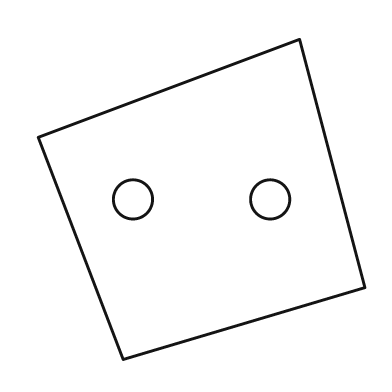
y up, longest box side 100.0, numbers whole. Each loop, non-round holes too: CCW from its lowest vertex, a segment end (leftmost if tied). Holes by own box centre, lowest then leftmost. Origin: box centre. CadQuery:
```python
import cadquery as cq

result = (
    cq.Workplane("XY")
    .moveTo(-24.0, -49.0)
    .lineTo(50.0, -27.0)
    .lineTo(30.0, 49.0)
    .lineTo(-50.0, 19.0)
    .close()
    .moveTo(-21.0, 0.0)
    .circle(6.0)
    .moveTo(21.0, 0.0)
    .circle(6.0)
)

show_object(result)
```